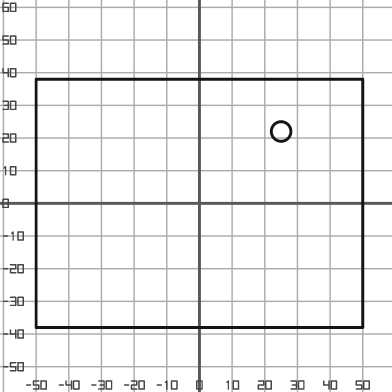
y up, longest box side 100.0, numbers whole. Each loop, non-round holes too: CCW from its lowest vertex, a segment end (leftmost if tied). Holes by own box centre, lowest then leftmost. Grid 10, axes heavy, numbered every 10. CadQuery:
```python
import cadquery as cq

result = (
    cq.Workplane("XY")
    .moveTo(-50.0, -38.0)
    .lineTo(50.0, -38.0)
    .lineTo(50.0, 38.0)
    .lineTo(-50.0, 38.0)
    .close()
    .moveTo(25.0, 22.0)
    .circle(3.0)
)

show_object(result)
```